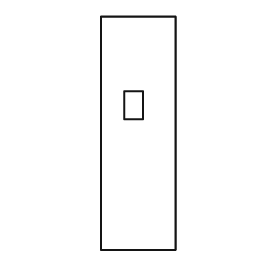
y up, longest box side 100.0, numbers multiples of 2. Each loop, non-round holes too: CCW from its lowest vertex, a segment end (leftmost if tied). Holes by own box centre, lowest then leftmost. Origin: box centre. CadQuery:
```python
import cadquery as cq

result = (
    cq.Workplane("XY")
    .moveTo(-16.0, -50.0)
    .lineTo(16.0, -50.0)
    .lineTo(16.0, 50.0)
    .lineTo(-16.0, 50.0)
    .close()
    .moveTo(-6.0, 6.0)
    .lineTo(2.0, 6.0)
    .lineTo(2.0, 18.0)
    .lineTo(-6.0, 18.0)
    .close()
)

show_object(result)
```